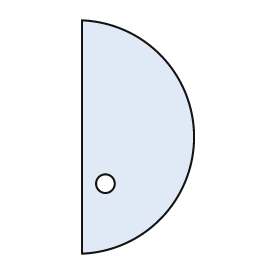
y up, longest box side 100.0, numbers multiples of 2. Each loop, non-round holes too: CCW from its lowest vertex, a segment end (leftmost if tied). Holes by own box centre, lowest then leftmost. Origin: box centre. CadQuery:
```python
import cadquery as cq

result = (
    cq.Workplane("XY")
    .moveTo(-24.0, -50.0)
    .threePointArc((24.0, 0.0), (-24.0, 50.0))
    .close()
    .moveTo(-14.0, -20.0)
    .circle(4.0)
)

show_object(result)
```